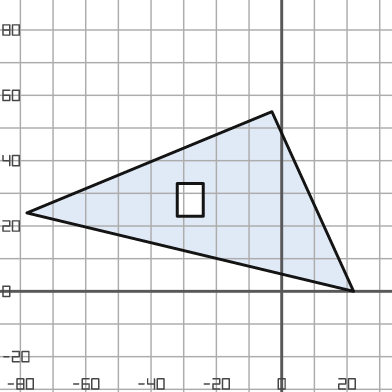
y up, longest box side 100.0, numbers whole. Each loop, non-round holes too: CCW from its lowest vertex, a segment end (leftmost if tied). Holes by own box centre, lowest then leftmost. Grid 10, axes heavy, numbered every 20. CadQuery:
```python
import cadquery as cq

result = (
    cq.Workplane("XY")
    .moveTo(22.0, 0.0)
    .lineTo(-3.0, 55.0)
    .lineTo(-78.0, 24.0)
    .close()
    .moveTo(-32.0, 23.0)
    .lineTo(-24.0, 23.0)
    .lineTo(-24.0, 33.0)
    .lineTo(-32.0, 33.0)
    .close()
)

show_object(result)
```